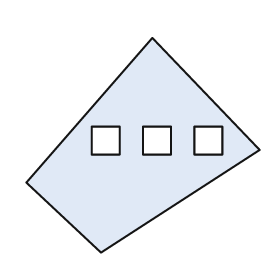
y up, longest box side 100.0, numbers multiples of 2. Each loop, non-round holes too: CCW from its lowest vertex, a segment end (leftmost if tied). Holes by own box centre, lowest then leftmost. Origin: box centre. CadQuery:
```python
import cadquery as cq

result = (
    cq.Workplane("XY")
    .moveTo(-18.0, -46.0)
    .lineTo(50.0, -2.0)
    .lineTo(4.0, 46.0)
    .lineTo(-50.0, -16.0)
    .close()
    .moveTo(-22.0, -4.0)
    .lineTo(-10.0, -4.0)
    .lineTo(-10.0, 8.0)
    .lineTo(-22.0, 8.0)
    .close()
    .moveTo(0.0, -4.0)
    .lineTo(12.0, -4.0)
    .lineTo(12.0, 8.0)
    .lineTo(0.0, 8.0)
    .close()
    .moveTo(22.0, -4.0)
    .lineTo(34.0, -4.0)
    .lineTo(34.0, 8.0)
    .lineTo(22.0, 8.0)
    .close()
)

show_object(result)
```